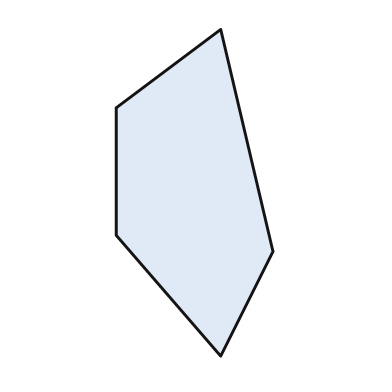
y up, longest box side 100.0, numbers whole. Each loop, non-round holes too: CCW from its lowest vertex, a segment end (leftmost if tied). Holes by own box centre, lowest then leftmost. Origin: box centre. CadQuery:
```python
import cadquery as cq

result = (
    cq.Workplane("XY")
    .moveTo(8.0, -50.0)
    .lineTo(24.0, -18.0)
    .lineTo(8.0, 50.0)
    .lineTo(-24.0, 26.0)
    .lineTo(-24.0, -13.0)
    .close()
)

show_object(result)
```